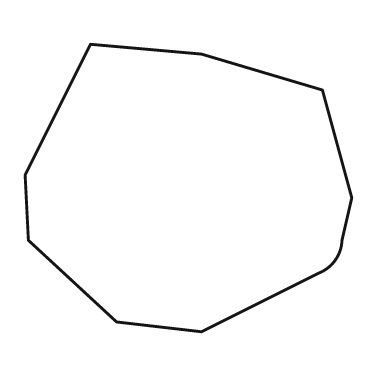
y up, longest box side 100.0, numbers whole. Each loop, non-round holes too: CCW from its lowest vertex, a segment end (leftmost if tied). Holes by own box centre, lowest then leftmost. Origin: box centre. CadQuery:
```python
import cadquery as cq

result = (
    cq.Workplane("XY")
    .moveTo(4.0, -44.0)
    .lineTo(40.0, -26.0)
    .threePointArc((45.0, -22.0), (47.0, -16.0))
    .lineTo(50.0, -3.0)
    .lineTo(41.0, 30.0)
    .lineTo(4.0, 41.0)
    .lineTo(-30.0, 44.0)
    .lineTo(-50.0, 4.0)
    .lineTo(-49.0, -16.0)
    .lineTo(-22.0, -41.0)
    .close()
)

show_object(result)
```